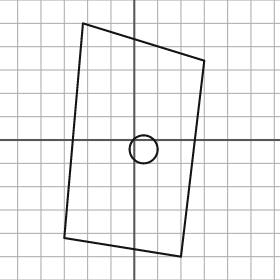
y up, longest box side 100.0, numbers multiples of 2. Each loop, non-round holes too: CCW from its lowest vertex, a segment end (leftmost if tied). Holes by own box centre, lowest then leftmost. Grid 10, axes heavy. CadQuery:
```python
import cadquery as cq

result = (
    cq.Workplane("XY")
    .moveTo(20.0, -50.0)
    .lineTo(30.0, 34.0)
    .lineTo(-22.0, 50.0)
    .lineTo(-30.0, -42.0)
    .close()
    .moveTo(4.0, -4.0)
    .circle(6.0)
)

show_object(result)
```